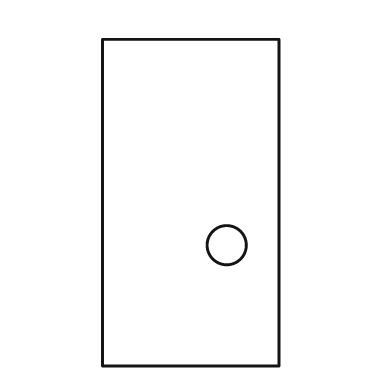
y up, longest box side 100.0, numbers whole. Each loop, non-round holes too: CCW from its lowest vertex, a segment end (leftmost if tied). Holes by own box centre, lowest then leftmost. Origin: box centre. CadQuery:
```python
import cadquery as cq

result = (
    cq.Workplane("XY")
    .moveTo(-27.0, -50.0)
    .lineTo(27.0, -50.0)
    .lineTo(27.0, 50.0)
    .lineTo(-27.0, 50.0)
    .close()
    .moveTo(11.0, -13.0)
    .circle(6.0)
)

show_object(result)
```